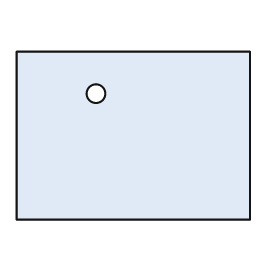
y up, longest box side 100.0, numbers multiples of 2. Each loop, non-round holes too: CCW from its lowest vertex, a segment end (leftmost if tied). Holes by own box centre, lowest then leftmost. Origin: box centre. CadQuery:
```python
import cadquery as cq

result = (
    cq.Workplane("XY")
    .moveTo(-50.0, -36.0)
    .lineTo(50.0, -36.0)
    .lineTo(50.0, 36.0)
    .lineTo(-50.0, 36.0)
    .close()
    .moveTo(-16.0, 18.0)
    .circle(4.0)
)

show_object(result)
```